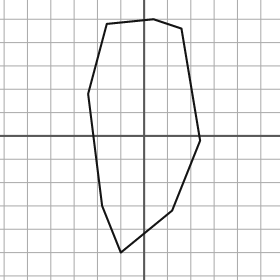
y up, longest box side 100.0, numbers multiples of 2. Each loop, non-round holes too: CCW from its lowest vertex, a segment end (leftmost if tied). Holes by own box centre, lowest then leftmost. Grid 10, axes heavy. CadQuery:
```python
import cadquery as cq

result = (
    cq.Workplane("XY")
    .moveTo(-10.0, -50.0)
    .lineTo(12.0, -32.0)
    .lineTo(24.0, -2.0)
    .lineTo(16.0, 46.0)
    .lineTo(4.0, 50.0)
    .lineTo(-16.0, 48.0)
    .lineTo(-24.0, 18.0)
    .lineTo(-18.0, -30.0)
    .close()
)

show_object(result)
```